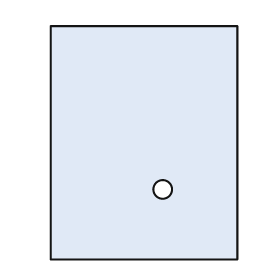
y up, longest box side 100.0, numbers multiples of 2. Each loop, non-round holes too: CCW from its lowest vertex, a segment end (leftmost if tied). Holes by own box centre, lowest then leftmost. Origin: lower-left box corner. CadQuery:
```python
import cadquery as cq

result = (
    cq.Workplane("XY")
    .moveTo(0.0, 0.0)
    .lineTo(80.0, 0.0)
    .lineTo(80.0, 100.0)
    .lineTo(0.0, 100.0)
    .close()
    .moveTo(48.0, 30.0)
    .circle(4.0)
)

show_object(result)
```